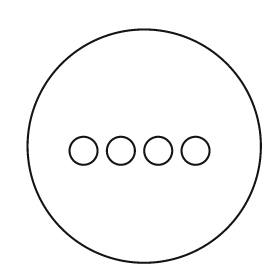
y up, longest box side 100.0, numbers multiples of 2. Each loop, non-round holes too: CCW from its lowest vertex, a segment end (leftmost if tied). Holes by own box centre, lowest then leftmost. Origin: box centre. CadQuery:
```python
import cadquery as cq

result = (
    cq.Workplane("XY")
    .moveTo(0.0, 0.0)
    .circle(50.0)
    .moveTo(-26.0, -2.0)
    .circle(6.0)
    .moveTo(-10.0, -2.0)
    .circle(6.0)
    .moveTo(6.0, -2.0)
    .circle(6.0)
    .moveTo(22.0, -2.0)
    .circle(6.0)
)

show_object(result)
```